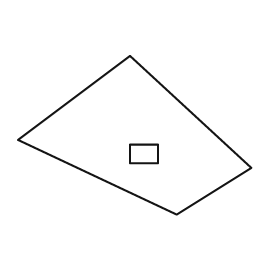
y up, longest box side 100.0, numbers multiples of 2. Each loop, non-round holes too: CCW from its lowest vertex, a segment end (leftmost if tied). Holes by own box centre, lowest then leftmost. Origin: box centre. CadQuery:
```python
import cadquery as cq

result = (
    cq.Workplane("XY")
    .moveTo(18.0, -34.0)
    .lineTo(50.0, -14.0)
    .lineTo(-2.0, 34.0)
    .lineTo(-50.0, -2.0)
    .close()
    .moveTo(-2.0, -12.0)
    .lineTo(10.0, -12.0)
    .lineTo(10.0, -4.0)
    .lineTo(-2.0, -4.0)
    .close()
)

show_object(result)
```